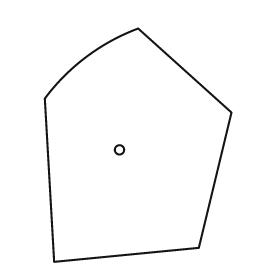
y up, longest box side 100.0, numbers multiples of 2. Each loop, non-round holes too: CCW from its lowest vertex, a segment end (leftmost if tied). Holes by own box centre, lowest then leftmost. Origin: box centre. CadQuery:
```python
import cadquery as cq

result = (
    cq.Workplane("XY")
    .moveTo(-36.0, -50.0)
    .lineTo(26.0, -44.0)
    .lineTo(40.0, 14.0)
    .lineTo(0.0, 50.0)
    .threePointArc((-22.0, 38.0), (-40.0, 20.0))
    .close()
    .moveTo(-8.0, -2.0)
    .circle(2.0)
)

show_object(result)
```